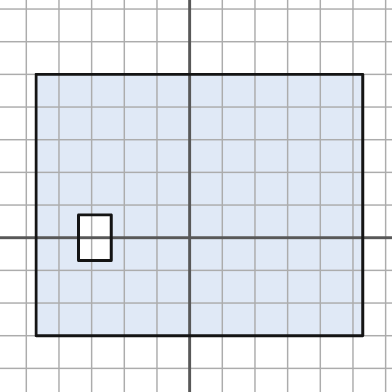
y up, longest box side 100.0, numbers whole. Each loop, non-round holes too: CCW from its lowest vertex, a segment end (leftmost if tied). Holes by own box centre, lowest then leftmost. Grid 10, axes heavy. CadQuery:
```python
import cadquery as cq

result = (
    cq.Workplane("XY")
    .moveTo(-47.0, -30.0)
    .lineTo(53.0, -30.0)
    .lineTo(53.0, 50.0)
    .lineTo(-47.0, 50.0)
    .close()
    .moveTo(-34.0, -7.0)
    .lineTo(-24.0, -7.0)
    .lineTo(-24.0, 7.0)
    .lineTo(-34.0, 7.0)
    .close()
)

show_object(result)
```